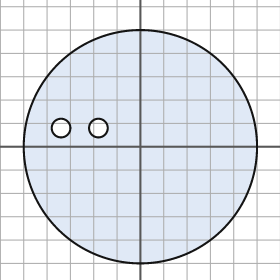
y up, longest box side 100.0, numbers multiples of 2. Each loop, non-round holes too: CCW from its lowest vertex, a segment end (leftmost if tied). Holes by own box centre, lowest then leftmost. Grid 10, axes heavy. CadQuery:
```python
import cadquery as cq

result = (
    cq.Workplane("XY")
    .moveTo(0.0, 0.0)
    .circle(50.0)
    .moveTo(-34.0, 8.0)
    .circle(4.0)
    .moveTo(-18.0, 8.0)
    .circle(4.0)
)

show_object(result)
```